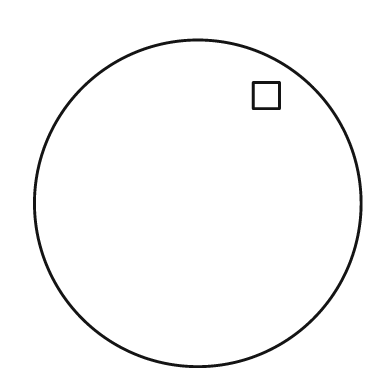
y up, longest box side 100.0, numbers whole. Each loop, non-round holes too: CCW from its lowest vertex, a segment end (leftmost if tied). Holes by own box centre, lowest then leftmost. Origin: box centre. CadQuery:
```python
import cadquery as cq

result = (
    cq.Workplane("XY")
    .moveTo(0.0, 0.0)
    .circle(50.0)
    .moveTo(17.0, 29.0)
    .lineTo(25.0, 29.0)
    .lineTo(25.0, 37.0)
    .lineTo(17.0, 37.0)
    .close()
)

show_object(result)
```